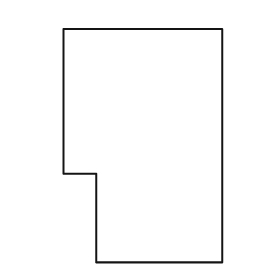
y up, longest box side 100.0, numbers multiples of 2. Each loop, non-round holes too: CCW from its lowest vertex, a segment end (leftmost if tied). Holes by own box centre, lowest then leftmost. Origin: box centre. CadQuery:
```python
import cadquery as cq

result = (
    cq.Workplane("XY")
    .moveTo(-20.0, -50.0)
    .lineTo(34.0, -50.0)
    .lineTo(34.0, 50.0)
    .lineTo(-34.0, 50.0)
    .lineTo(-34.0, -12.0)
    .lineTo(-20.0, -12.0)
    .close()
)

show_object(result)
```